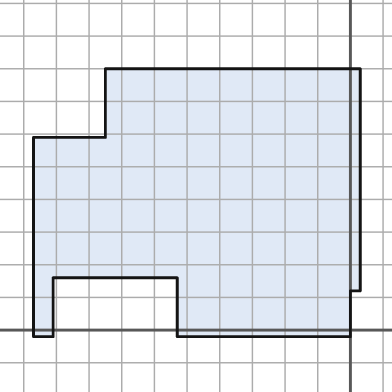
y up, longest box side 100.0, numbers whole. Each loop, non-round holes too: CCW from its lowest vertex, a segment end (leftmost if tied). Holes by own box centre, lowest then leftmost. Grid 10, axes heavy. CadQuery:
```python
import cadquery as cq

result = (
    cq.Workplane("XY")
    .moveTo(-97.0, -2.0)
    .lineTo(-91.0, -2.0)
    .lineTo(-91.0, 16.0)
    .lineTo(-53.0, 16.0)
    .lineTo(-53.0, -2.0)
    .lineTo(0.0, -2.0)
    .lineTo(0.0, 12.0)
    .lineTo(3.0, 12.0)
    .lineTo(3.0, 80.0)
    .lineTo(-75.0, 80.0)
    .lineTo(-75.0, 59.0)
    .lineTo(-97.0, 59.0)
    .close()
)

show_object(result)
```